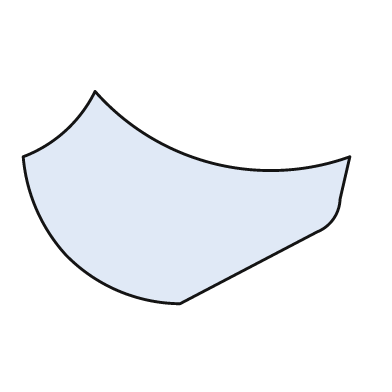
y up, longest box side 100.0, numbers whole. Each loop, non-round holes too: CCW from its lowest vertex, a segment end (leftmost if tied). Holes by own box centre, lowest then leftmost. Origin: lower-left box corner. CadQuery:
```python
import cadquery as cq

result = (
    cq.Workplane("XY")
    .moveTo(48.0, 0.0)
    .lineTo(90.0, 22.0)
    .threePointArc((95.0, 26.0), (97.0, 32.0))
    .lineTo(100.0, 45.0)
    .threePointArc((58.0, 43.0), (22.0, 65.0))
    .threePointArc((13.0, 53.0), (0.0, 45.0))
    .threePointArc((4.0, 29.0), (13.0, 15.0))
    .threePointArc((29.0, 4.0), (48.0, 0.0))
    .close()
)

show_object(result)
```